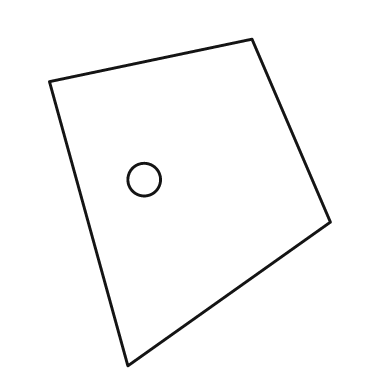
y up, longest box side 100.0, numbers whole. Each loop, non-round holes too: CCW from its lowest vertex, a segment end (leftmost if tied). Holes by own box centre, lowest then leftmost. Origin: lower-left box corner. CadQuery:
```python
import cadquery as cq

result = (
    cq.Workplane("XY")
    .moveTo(24.0, 0.0)
    .lineTo(86.0, 44.0)
    .lineTo(62.0, 100.0)
    .lineTo(0.0, 87.0)
    .close()
    .moveTo(29.0, 57.0)
    .circle(5.0)
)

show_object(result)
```